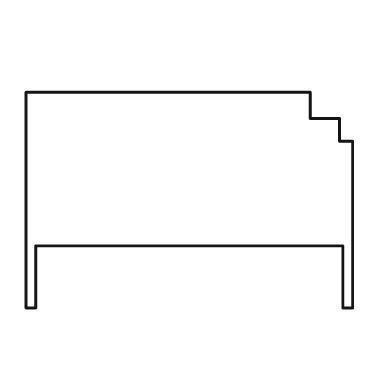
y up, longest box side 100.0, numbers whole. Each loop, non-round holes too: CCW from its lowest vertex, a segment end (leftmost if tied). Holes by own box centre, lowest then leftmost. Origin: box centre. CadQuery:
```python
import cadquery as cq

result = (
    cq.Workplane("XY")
    .moveTo(-50.0, -33.0)
    .lineTo(-47.0, -33.0)
    .lineTo(-47.0, -14.0)
    .lineTo(47.0, -14.0)
    .lineTo(47.0, -33.0)
    .lineTo(50.0, -33.0)
    .lineTo(50.0, 18.0)
    .lineTo(46.0, 18.0)
    .lineTo(46.0, 25.0)
    .lineTo(37.0, 25.0)
    .lineTo(37.0, 33.0)
    .lineTo(-50.0, 33.0)
    .close()
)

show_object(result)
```